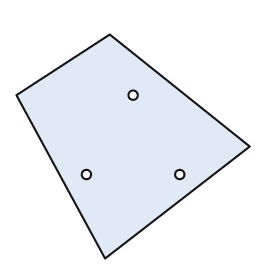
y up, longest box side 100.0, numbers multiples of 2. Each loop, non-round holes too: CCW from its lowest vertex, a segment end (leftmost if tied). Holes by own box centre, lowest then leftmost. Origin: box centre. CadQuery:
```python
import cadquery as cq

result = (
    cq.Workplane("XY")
    .moveTo(-12.0, -48.0)
    .lineTo(50.0, 0.0)
    .lineTo(-10.0, 48.0)
    .lineTo(-50.0, 22.0)
    .close()
    .moveTo(-20.0, -12.0)
    .circle(2.0)
    .moveTo(20.0, -12.0)
    .circle(2.0)
    .moveTo(0.0, 22.0)
    .circle(2.0)
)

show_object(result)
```